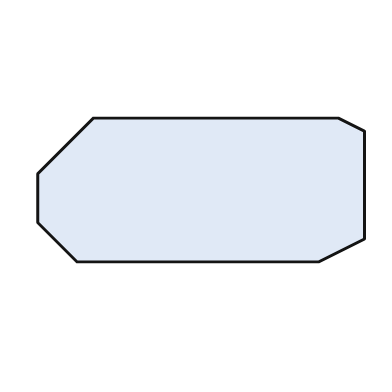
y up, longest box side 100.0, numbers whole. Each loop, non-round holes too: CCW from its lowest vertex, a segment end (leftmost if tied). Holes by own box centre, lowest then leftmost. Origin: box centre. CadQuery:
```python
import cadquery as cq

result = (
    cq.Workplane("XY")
    .moveTo(-38.0, -22.0)
    .lineTo(36.0, -22.0)
    .lineTo(50.0, -15.0)
    .lineTo(50.0, 18.0)
    .lineTo(42.0, 22.0)
    .lineTo(-33.0, 22.0)
    .lineTo(-50.0, 5.0)
    .lineTo(-50.0, -10.0)
    .close()
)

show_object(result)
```